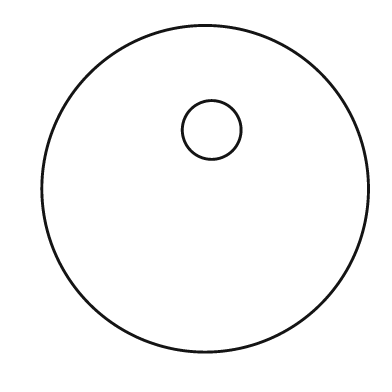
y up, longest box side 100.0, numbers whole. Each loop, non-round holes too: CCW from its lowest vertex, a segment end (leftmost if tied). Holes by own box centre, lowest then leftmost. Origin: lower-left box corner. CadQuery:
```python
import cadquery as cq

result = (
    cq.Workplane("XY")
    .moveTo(50.0, 50.0)
    .circle(50.0)
    .moveTo(52.0, 68.0)
    .circle(9.0)
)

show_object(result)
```